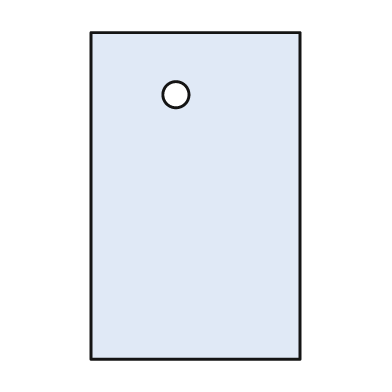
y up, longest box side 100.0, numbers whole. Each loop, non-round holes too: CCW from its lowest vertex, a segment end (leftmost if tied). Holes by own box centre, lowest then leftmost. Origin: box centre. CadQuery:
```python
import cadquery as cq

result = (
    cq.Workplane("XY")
    .moveTo(-32.0, -50.0)
    .lineTo(32.0, -50.0)
    .lineTo(32.0, 50.0)
    .lineTo(-32.0, 50.0)
    .close()
    .moveTo(-6.0, 31.0)
    .circle(4.0)
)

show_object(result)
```